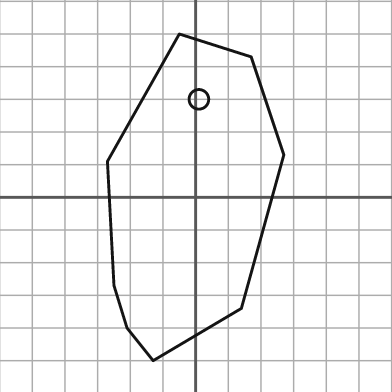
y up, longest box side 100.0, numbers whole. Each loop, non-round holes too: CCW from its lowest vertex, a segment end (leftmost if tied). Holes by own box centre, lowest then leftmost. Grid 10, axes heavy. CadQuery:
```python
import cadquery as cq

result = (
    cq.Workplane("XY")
    .moveTo(-13.0, -50.0)
    .lineTo(14.0, -34.0)
    .lineTo(27.0, 13.0)
    .lineTo(17.0, 43.0)
    .lineTo(-5.0, 50.0)
    .lineTo(-27.0, 11.0)
    .lineTo(-25.0, -27.0)
    .lineTo(-21.0, -40.0)
    .close()
    .moveTo(1.0, 30.0)
    .circle(3.0)
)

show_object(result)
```